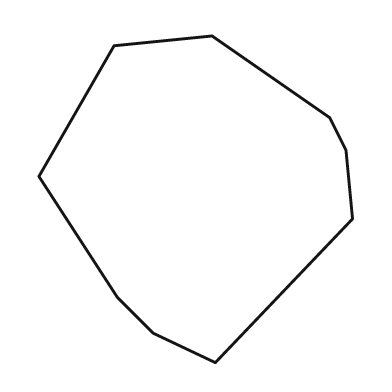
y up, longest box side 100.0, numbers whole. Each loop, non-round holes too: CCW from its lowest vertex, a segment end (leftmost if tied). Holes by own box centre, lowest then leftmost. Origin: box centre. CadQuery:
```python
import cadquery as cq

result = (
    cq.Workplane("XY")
    .moveTo(6.0, -50.0)
    .lineTo(48.0, -6.0)
    .lineTo(46.0, 15.0)
    .lineTo(41.0, 25.0)
    .lineTo(5.0, 50.0)
    .lineTo(-25.0, 47.0)
    .lineTo(-48.0, 7.0)
    .lineTo(-24.0, -30.0)
    .lineTo(-13.0, -41.0)
    .close()
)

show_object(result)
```